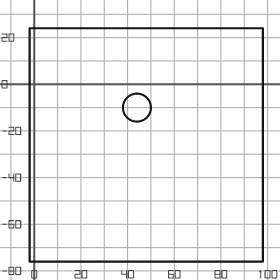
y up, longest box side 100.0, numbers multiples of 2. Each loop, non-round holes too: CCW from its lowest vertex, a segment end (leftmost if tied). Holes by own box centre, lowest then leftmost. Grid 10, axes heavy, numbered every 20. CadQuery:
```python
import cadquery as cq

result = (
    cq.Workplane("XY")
    .moveTo(-2.0, -76.0)
    .lineTo(98.0, -76.0)
    .lineTo(98.0, 24.0)
    .lineTo(-2.0, 24.0)
    .close()
    .moveTo(44.0, -10.0)
    .circle(6.0)
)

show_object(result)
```